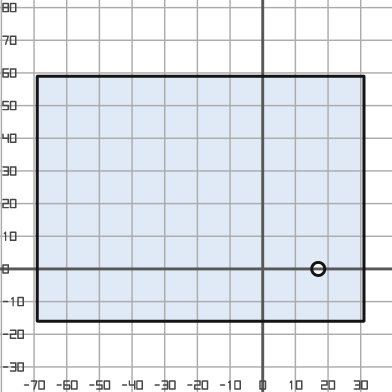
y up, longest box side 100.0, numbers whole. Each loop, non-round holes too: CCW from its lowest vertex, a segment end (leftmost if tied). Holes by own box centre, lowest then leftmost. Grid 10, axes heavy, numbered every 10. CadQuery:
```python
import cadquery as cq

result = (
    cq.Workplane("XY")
    .moveTo(-69.0, -16.0)
    .lineTo(31.0, -16.0)
    .lineTo(31.0, 59.0)
    .lineTo(-69.0, 59.0)
    .close()
    .moveTo(17.0, 0.0)
    .circle(2.0)
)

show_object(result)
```